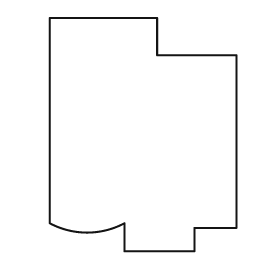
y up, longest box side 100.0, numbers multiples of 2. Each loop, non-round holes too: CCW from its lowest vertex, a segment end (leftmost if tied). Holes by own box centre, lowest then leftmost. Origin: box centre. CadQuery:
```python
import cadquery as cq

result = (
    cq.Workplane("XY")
    .moveTo(-8.0, -50.0)
    .lineTo(22.0, -50.0)
    .lineTo(22.0, -40.0)
    .lineTo(40.0, -40.0)
    .lineTo(40.0, 34.0)
    .lineTo(6.0, 34.0)
    .lineTo(6.0, 50.0)
    .lineTo(-40.0, 50.0)
    .lineTo(-40.0, -38.0)
    .threePointArc((-24.0, -42.0), (-8.0, -38.0))
    .close()
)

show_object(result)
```